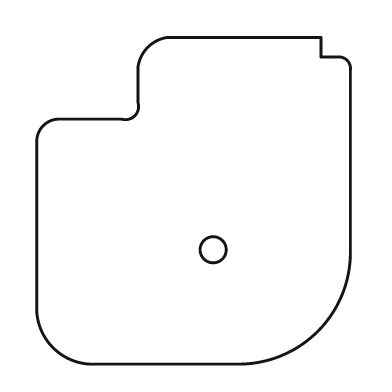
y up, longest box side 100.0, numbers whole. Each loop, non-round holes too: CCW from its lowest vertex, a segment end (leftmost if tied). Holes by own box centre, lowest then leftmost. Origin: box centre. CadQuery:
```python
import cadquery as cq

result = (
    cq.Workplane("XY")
    .moveTo(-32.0, -50.0)
    .lineTo(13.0, -50.0)
    .threePointArc((38.0, -40.0), (48.0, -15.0))
    .lineTo(48.0, 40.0)
    .threePointArc((47.0, 43.0), (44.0, 44.0))
    .lineTo(39.0, 44.0)
    .lineTo(39.0, 50.0)
    .lineTo(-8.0, 50.0)
    .threePointArc((-14.0, 47.0), (-17.0, 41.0))
    .lineTo(-17.0, 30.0)
    .threePointArc((-18.0, 26.0), (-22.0, 25.0))
    .lineTo(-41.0, 25.0)
    .threePointArc((-46.0, 23.0), (-48.0, 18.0))
    .lineTo(-48.0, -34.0)
    .threePointArc((-43.0, -45.0), (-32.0, -50.0))
    .close()
    .moveTo(6.0, -15.0)
    .circle(4.0)
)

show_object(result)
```